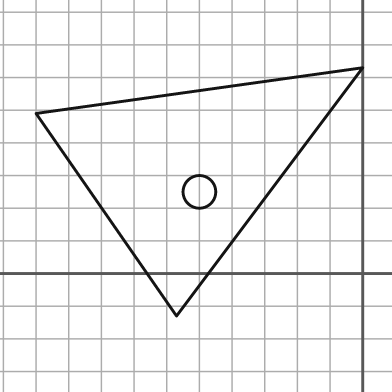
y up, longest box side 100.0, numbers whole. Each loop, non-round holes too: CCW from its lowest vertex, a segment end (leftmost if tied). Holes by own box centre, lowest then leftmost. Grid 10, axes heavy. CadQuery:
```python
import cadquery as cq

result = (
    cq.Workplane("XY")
    .moveTo(-57.0, -13.0)
    .lineTo(0.0, 63.0)
    .lineTo(-100.0, 49.0)
    .close()
    .moveTo(-50.0, 25.0)
    .circle(5.0)
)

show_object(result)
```